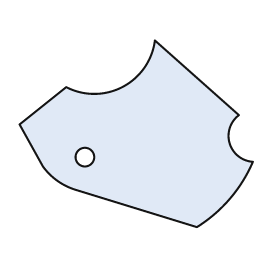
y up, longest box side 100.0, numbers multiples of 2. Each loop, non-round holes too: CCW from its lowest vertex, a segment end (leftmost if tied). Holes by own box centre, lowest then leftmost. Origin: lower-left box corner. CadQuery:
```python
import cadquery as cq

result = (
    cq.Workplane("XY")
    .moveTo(76.0, 0.0)
    .threePointArc((90.0, 12.0), (100.0, 28.0))
    .threePointArc((90.0, 36.0), (94.0, 48.0))
    .lineTo(58.0, 80.0)
    .threePointArc((44.0, 60.0), (20.0, 60.0))
    .lineTo(0.0, 44.0)
    .lineTo(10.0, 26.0)
    .threePointArc((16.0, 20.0), (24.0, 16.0))
    .close()
    .moveTo(28.0, 30.0)
    .circle(4.0)
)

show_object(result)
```